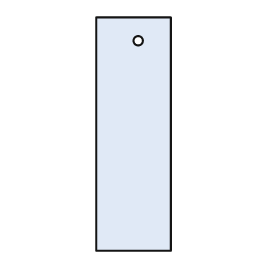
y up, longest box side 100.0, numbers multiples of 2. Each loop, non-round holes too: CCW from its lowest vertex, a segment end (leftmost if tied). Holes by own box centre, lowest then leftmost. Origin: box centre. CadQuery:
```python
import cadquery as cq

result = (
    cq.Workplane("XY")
    .moveTo(-16.0, -50.0)
    .lineTo(16.0, -50.0)
    .lineTo(16.0, 50.0)
    .lineTo(-16.0, 50.0)
    .close()
    .moveTo(2.0, 40.0)
    .circle(2.0)
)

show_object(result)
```